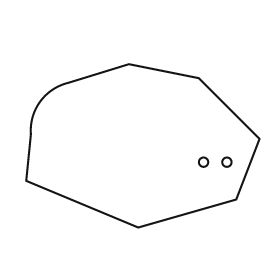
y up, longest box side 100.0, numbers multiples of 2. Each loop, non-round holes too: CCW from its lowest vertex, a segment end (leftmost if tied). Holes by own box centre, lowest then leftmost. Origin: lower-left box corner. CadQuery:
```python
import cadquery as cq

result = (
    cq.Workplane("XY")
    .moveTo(48.0, 0.0)
    .lineTo(90.0, 12.0)
    .lineTo(100.0, 38.0)
    .lineTo(74.0, 64.0)
    .lineTo(44.0, 70.0)
    .lineTo(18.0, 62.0)
    .threePointArc((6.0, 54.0), (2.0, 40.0))
    .lineTo(0.0, 20.0)
    .close()
    .moveTo(76.0, 28.0)
    .circle(2.0)
    .moveTo(86.0, 28.0)
    .circle(2.0)
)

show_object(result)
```